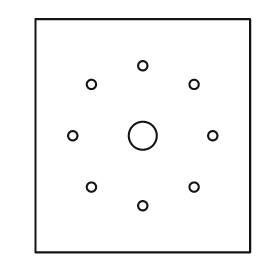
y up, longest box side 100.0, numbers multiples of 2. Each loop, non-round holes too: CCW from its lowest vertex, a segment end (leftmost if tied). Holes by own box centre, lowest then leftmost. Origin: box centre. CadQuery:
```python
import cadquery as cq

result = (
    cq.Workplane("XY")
    .moveTo(-46.0, -50.0)
    .lineTo(46.0, -50.0)
    .lineTo(46.0, 50.0)
    .lineTo(-46.0, 50.0)
    .close()
    .moveTo(0.0, -30.0)
    .circle(2.0)
    .moveTo(-22.0, -22.0)
    .circle(2.0)
    .moveTo(22.0, -22.0)
    .circle(2.0)
    .moveTo(-30.0, 0.0)
    .circle(2.0)
    .moveTo(0.0, 0.0)
    .circle(6.0)
    .moveTo(30.0, 0.0)
    .circle(2.0)
    .moveTo(-22.0, 22.0)
    .circle(2.0)
    .moveTo(22.0, 22.0)
    .circle(2.0)
    .moveTo(0.0, 30.0)
    .circle(2.0)
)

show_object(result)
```